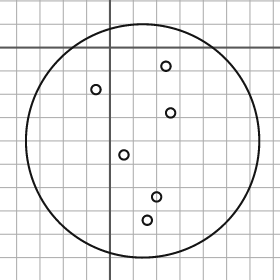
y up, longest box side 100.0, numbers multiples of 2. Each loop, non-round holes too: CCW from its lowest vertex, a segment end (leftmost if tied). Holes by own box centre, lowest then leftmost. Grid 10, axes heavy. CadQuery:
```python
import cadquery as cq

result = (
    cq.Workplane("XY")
    .moveTo(14.0, -40.0)
    .circle(50.0)
    .moveTo(16.0, -74.0)
    .circle(2.0)
    .moveTo(20.0, -64.0)
    .circle(2.0)
    .moveTo(6.0, -46.0)
    .circle(2.0)
    .moveTo(26.0, -28.0)
    .circle(2.0)
    .moveTo(-6.0, -18.0)
    .circle(2.0)
    .moveTo(24.0, -8.0)
    .circle(2.0)
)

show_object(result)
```